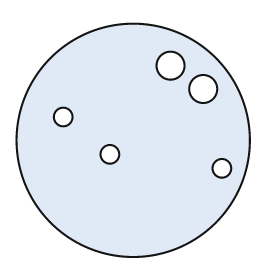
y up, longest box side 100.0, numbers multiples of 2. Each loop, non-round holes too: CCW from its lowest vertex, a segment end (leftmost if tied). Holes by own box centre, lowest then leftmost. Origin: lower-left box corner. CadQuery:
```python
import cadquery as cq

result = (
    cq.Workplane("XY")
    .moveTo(50.0, 50.0)
    .circle(50.0)
    .moveTo(88.0, 38.0)
    .circle(4.0)
    .moveTo(40.0, 44.0)
    .circle(4.0)
    .moveTo(20.0, 60.0)
    .circle(4.0)
    .moveTo(80.0, 72.0)
    .circle(6.0)
    .moveTo(66.0, 82.0)
    .circle(6.0)
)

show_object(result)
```